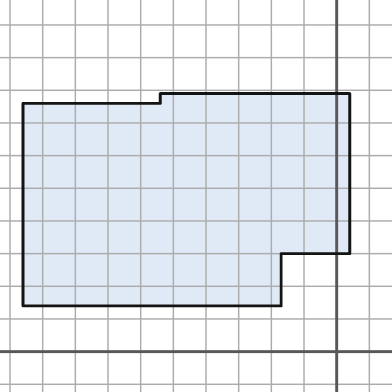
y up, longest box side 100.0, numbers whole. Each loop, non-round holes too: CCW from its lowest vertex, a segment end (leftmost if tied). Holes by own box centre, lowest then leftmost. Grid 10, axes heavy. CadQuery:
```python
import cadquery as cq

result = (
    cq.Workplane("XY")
    .moveTo(-96.0, 14.0)
    .lineTo(-17.0, 14.0)
    .lineTo(-17.0, 30.0)
    .lineTo(4.0, 30.0)
    .lineTo(4.0, 79.0)
    .lineTo(-54.0, 79.0)
    .lineTo(-54.0, 76.0)
    .lineTo(-96.0, 76.0)
    .close()
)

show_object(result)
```